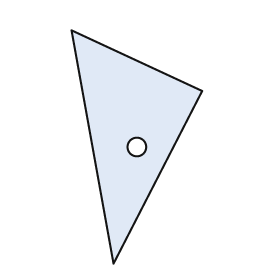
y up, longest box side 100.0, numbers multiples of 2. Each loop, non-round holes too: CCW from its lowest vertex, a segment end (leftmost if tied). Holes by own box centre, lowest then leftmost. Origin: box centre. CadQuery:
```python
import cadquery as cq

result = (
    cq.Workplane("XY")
    .moveTo(-10.0, -50.0)
    .lineTo(28.0, 24.0)
    .lineTo(-28.0, 50.0)
    .close()
    .moveTo(0.0, 0.0)
    .circle(4.0)
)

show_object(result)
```